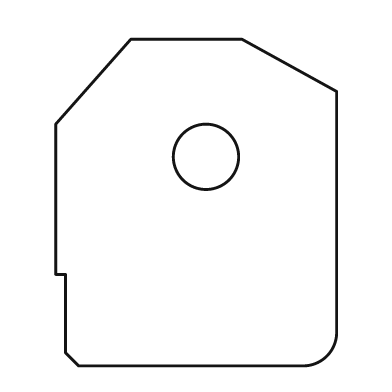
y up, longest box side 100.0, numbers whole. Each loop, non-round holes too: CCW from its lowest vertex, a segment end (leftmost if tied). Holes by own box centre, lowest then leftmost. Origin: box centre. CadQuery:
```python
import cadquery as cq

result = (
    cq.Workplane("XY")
    .moveTo(-36.0, -50.0)
    .lineTo(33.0, -50.0)
    .threePointArc((40.0, -47.0), (43.0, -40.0))
    .lineTo(43.0, 34.0)
    .lineTo(14.0, 50.0)
    .lineTo(-20.0, 50.0)
    .lineTo(-43.0, 24.0)
    .lineTo(-43.0, -22.0)
    .lineTo(-40.0, -22.0)
    .lineTo(-40.0, -46.0)
    .close()
    .moveTo(3.0, 14.0)
    .circle(10.0)
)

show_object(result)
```